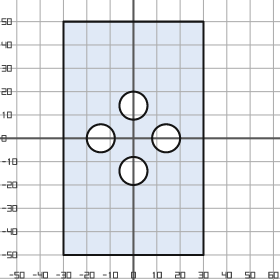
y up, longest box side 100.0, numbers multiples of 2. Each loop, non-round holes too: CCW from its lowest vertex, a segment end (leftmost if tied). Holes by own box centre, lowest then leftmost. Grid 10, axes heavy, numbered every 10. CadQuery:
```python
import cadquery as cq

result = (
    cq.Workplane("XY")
    .moveTo(-30.0, -50.0)
    .lineTo(30.0, -50.0)
    .lineTo(30.0, 50.0)
    .lineTo(-30.0, 50.0)
    .close()
    .moveTo(0.0, -14.0)
    .circle(6.0)
    .moveTo(-14.0, 0.0)
    .circle(6.0)
    .moveTo(14.0, 0.0)
    .circle(6.0)
    .moveTo(0.0, 14.0)
    .circle(6.0)
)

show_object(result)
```